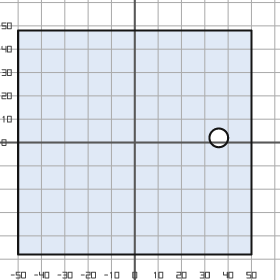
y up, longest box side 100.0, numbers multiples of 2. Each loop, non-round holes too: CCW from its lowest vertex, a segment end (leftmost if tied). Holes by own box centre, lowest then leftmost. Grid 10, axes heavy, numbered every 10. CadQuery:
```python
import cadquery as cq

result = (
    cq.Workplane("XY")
    .moveTo(-50.0, -48.0)
    .lineTo(50.0, -48.0)
    .lineTo(50.0, 48.0)
    .lineTo(-50.0, 48.0)
    .close()
    .moveTo(36.0, 2.0)
    .circle(4.0)
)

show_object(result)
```